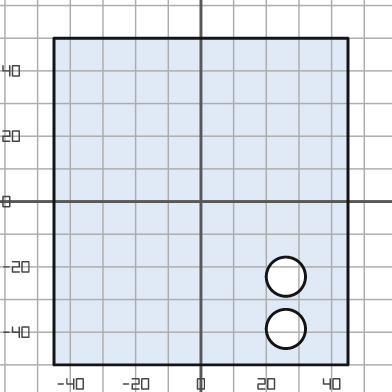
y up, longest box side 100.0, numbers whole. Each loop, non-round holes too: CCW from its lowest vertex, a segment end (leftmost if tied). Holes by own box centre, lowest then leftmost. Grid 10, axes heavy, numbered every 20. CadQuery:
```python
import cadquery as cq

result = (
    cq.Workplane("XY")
    .moveTo(-45.0, -50.0)
    .lineTo(45.0, -50.0)
    .lineTo(45.0, 50.0)
    .lineTo(-45.0, 50.0)
    .close()
    .moveTo(26.0, -39.0)
    .circle(6.0)
    .moveTo(26.0, -23.0)
    .circle(6.0)
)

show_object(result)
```